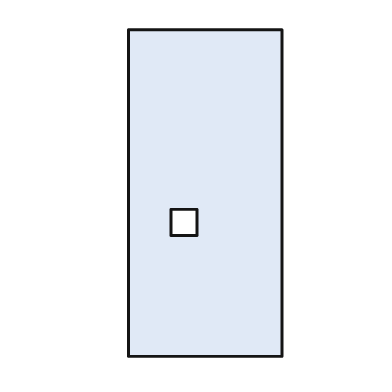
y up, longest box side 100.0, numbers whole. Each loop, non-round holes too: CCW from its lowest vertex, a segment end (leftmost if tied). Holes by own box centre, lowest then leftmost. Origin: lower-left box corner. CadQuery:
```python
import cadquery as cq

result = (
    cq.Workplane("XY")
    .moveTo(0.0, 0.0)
    .lineTo(47.0, 0.0)
    .lineTo(47.0, 100.0)
    .lineTo(0.0, 100.0)
    .close()
    .moveTo(13.0, 37.0)
    .lineTo(21.0, 37.0)
    .lineTo(21.0, 45.0)
    .lineTo(13.0, 45.0)
    .close()
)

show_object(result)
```